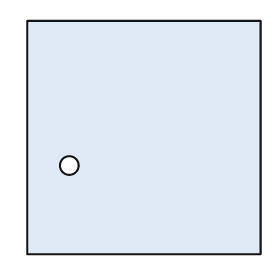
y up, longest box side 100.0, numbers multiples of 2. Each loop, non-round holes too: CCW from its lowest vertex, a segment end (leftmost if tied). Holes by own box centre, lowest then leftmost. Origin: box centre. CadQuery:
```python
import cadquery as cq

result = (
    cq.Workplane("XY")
    .moveTo(-50.0, -50.0)
    .lineTo(50.0, -50.0)
    .lineTo(50.0, 50.0)
    .lineTo(-50.0, 50.0)
    .close()
    .moveTo(-32.0, -12.0)
    .circle(4.0)
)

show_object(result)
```